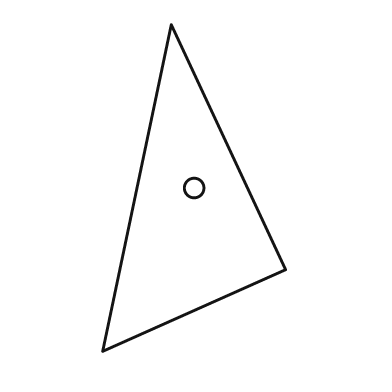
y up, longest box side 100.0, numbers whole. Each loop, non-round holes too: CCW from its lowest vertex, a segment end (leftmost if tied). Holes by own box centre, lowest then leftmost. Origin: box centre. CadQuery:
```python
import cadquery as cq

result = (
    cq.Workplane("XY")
    .moveTo(-28.0, -50.0)
    .lineTo(28.0, -25.0)
    .lineTo(-7.0, 50.0)
    .close()
    .moveTo(0.0, 0.0)
    .circle(3.0)
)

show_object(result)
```